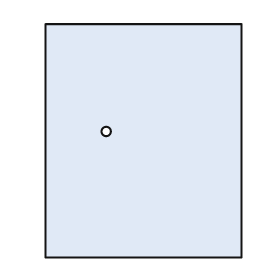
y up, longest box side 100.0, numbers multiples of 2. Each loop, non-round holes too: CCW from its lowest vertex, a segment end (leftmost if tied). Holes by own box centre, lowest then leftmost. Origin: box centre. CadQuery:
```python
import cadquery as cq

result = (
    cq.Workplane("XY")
    .moveTo(-42.0, -50.0)
    .lineTo(42.0, -50.0)
    .lineTo(42.0, 50.0)
    .lineTo(-42.0, 50.0)
    .close()
    .moveTo(-16.0, 4.0)
    .circle(2.0)
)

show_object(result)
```